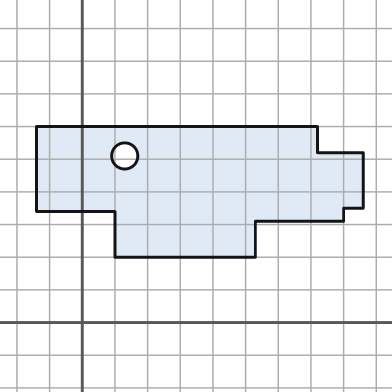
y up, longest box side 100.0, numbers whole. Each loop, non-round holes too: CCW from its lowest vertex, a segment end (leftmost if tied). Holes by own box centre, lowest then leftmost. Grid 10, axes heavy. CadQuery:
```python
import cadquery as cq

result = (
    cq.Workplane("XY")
    .moveTo(10.0, 20.0)
    .lineTo(53.0, 20.0)
    .lineTo(53.0, 31.0)
    .lineTo(80.0, 31.0)
    .lineTo(80.0, 35.0)
    .lineTo(86.0, 35.0)
    .lineTo(86.0, 52.0)
    .lineTo(72.0, 52.0)
    .lineTo(72.0, 60.0)
    .lineTo(-14.0, 60.0)
    .lineTo(-14.0, 34.0)
    .lineTo(10.0, 34.0)
    .close()
    .moveTo(13.0, 51.0)
    .circle(4.0)
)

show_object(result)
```